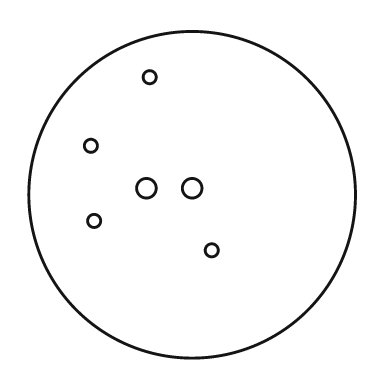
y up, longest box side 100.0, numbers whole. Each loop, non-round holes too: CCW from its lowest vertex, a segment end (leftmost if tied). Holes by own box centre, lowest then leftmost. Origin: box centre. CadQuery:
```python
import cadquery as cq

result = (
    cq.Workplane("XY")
    .moveTo(0.0, 0.0)
    .circle(50.0)
    .moveTo(6.0, -17.0)
    .circle(2.0)
    .moveTo(-30.0, -8.0)
    .circle(2.0)
    .moveTo(-14.0, 2.0)
    .circle(3.0)
    .moveTo(0.0, 2.0)
    .circle(3.0)
    .moveTo(-31.0, 15.0)
    .circle(2.0)
    .moveTo(-13.0, 36.0)
    .circle(2.0)
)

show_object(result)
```